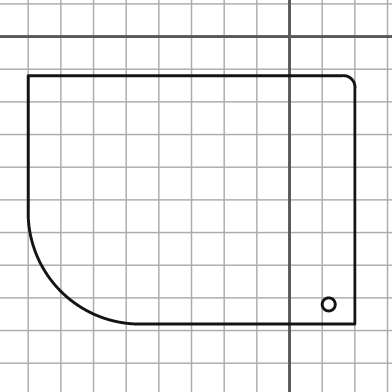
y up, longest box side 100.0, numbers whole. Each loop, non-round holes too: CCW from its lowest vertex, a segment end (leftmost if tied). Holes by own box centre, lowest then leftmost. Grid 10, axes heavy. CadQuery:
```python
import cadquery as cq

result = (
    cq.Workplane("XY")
    .moveTo(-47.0, -88.0)
    .lineTo(20.0, -88.0)
    .lineTo(20.0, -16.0)
    .threePointArc((19.0, -13.0), (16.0, -12.0))
    .lineTo(-80.0, -12.0)
    .lineTo(-80.0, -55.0)
    .threePointArc((-70.0, -78.0), (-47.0, -88.0))
    .close()
    .moveTo(12.0, -82.0)
    .circle(2.0)
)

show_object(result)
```